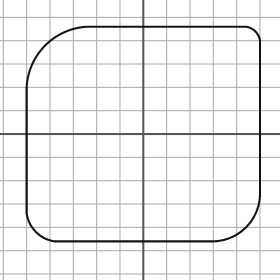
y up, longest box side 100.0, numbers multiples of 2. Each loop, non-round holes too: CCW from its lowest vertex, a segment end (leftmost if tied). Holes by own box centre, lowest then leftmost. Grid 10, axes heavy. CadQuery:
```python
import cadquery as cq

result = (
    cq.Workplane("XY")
    .moveTo(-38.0, -46.0)
    .lineTo(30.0, -46.0)
    .threePointArc((44.0, -40.0), (50.0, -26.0))
    .lineTo(50.0, 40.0)
    .threePointArc((48.0, 44.0), (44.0, 46.0))
    .lineTo(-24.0, 46.0)
    .threePointArc((-42.0, 38.0), (-50.0, 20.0))
    .lineTo(-50.0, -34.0)
    .threePointArc((-46.0, -42.0), (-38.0, -46.0))
    .close()
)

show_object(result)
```